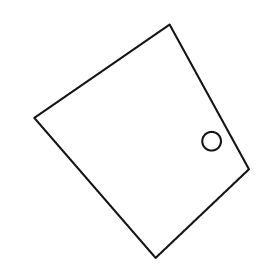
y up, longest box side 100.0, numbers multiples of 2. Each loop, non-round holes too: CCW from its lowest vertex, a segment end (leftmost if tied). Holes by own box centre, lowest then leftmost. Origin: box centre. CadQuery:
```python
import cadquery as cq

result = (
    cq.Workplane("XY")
    .moveTo(6.0, -50.0)
    .lineTo(46.0, -12.0)
    .lineTo(12.0, 50.0)
    .lineTo(-46.0, 10.0)
    .close()
    .moveTo(30.0, 0.0)
    .circle(4.0)
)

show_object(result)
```